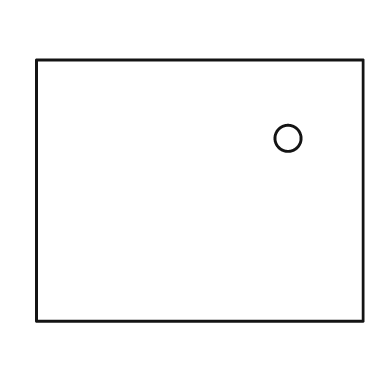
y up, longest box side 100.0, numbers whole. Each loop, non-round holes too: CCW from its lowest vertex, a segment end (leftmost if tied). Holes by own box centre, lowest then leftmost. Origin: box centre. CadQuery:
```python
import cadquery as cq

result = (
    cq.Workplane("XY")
    .moveTo(-50.0, -40.0)
    .lineTo(50.0, -40.0)
    .lineTo(50.0, 40.0)
    .lineTo(-50.0, 40.0)
    .close()
    .moveTo(27.0, 16.0)
    .circle(4.0)
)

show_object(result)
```